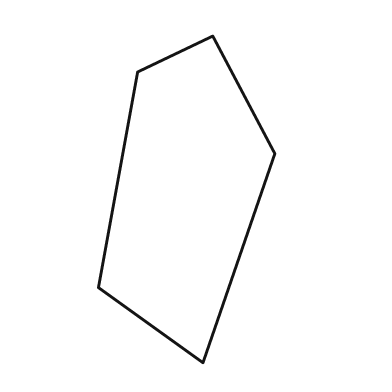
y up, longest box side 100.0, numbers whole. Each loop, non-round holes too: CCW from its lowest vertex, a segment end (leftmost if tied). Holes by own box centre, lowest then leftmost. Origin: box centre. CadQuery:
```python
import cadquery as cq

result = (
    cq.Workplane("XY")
    .moveTo(5.0, -50.0)
    .lineTo(27.0, 14.0)
    .lineTo(8.0, 50.0)
    .lineTo(-15.0, 39.0)
    .lineTo(-27.0, -27.0)
    .close()
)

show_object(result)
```